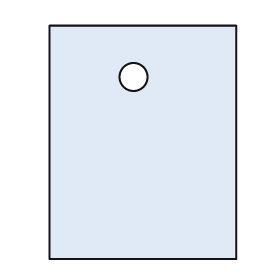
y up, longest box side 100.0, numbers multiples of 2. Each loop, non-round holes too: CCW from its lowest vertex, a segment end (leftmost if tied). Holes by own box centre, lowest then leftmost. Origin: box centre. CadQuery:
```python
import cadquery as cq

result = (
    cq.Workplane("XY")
    .moveTo(-40.0, -50.0)
    .lineTo(40.0, -50.0)
    .lineTo(40.0, 50.0)
    .lineTo(-40.0, 50.0)
    .close()
    .moveTo(-4.0, 28.0)
    .circle(6.0)
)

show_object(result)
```